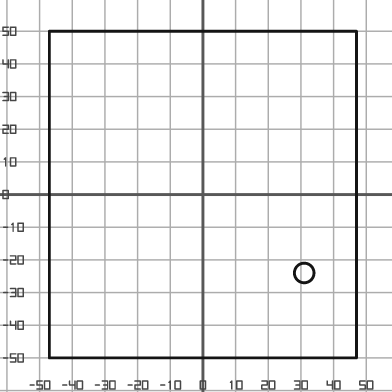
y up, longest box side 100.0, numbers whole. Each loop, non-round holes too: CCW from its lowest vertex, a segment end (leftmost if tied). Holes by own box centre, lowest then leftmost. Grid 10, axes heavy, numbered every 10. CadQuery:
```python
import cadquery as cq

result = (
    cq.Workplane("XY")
    .moveTo(-47.0, -50.0)
    .lineTo(47.0, -50.0)
    .lineTo(47.0, 50.0)
    .lineTo(-47.0, 50.0)
    .close()
    .moveTo(31.0, -24.0)
    .circle(3.0)
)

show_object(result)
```